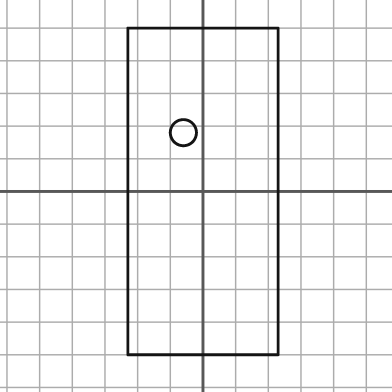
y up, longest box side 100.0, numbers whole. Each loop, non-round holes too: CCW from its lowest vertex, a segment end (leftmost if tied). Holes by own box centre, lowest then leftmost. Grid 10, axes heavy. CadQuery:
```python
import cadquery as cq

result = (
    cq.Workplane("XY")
    .moveTo(-23.0, -50.0)
    .lineTo(23.0, -50.0)
    .lineTo(23.0, 50.0)
    .lineTo(-23.0, 50.0)
    .close()
    .moveTo(-6.0, 18.0)
    .circle(4.0)
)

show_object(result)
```